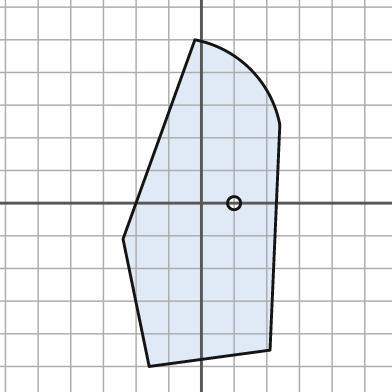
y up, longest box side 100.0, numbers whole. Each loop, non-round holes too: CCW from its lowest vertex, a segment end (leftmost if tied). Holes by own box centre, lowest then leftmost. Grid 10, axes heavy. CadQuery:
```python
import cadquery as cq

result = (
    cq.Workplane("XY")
    .moveTo(-16.0, -50.0)
    .lineTo(21.0, -45.0)
    .lineTo(24.0, 24.0)
    .threePointArc((15.0, 41.0), (-2.0, 50.0))
    .lineTo(-24.0, -11.0)
    .close()
    .moveTo(10.0, 0.0)
    .circle(2.0)
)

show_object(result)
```